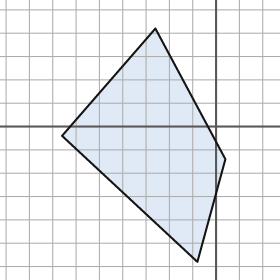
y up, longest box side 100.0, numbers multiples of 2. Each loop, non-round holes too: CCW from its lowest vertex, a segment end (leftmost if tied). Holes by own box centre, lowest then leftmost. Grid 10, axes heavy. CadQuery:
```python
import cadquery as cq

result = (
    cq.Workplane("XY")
    .moveTo(-8.0, -58.0)
    .lineTo(4.0, -14.0)
    .lineTo(-26.0, 42.0)
    .lineTo(-66.0, -4.0)
    .close()
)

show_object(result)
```